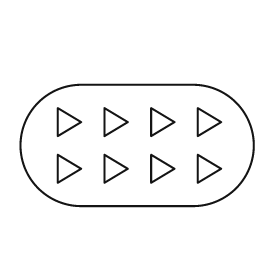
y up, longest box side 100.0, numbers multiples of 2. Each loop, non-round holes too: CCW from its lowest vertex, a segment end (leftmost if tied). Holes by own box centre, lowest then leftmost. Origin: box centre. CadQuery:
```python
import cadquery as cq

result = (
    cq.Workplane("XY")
    .moveTo(-24.0, -26.0)
    .lineTo(24.0, -26.0)
    .threePointArc((50.0, 0.0), (24.0, 26.0))
    .lineTo(-24.0, 26.0)
    .threePointArc((-50.0, 0.0), (-24.0, -26.0))
    .close()
    .moveTo(-34.0, -16.0)
    .lineTo(-24.0, -10.0)
    .lineTo(-34.0, -4.0)
    .close()
    .moveTo(-14.0, -16.0)
    .lineTo(-4.0, -10.0)
    .lineTo(-14.0, -4.0)
    .close()
    .moveTo(6.0, -16.0)
    .lineTo(16.0, -10.0)
    .lineTo(6.0, -4.0)
    .close()
    .moveTo(26.0, -16.0)
    .lineTo(36.0, -10.0)
    .lineTo(26.0, -4.0)
    .close()
    .moveTo(-34.0, 4.0)
    .lineTo(-24.0, 10.0)
    .lineTo(-34.0, 16.0)
    .close()
    .moveTo(-14.0, 4.0)
    .lineTo(-4.0, 10.0)
    .lineTo(-14.0, 16.0)
    .close()
    .moveTo(6.0, 4.0)
    .lineTo(16.0, 10.0)
    .lineTo(6.0, 16.0)
    .close()
    .moveTo(26.0, 4.0)
    .lineTo(36.0, 10.0)
    .lineTo(26.0, 16.0)
    .close()
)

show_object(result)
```